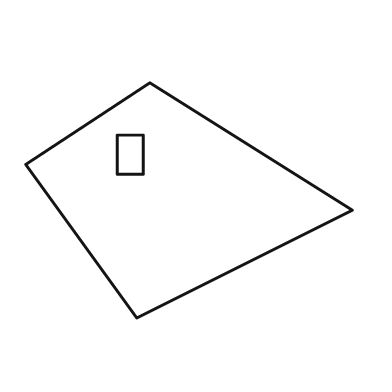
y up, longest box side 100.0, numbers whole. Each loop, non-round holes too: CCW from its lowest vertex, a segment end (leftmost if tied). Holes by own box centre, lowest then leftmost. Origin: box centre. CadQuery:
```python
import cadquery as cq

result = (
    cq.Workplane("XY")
    .moveTo(-16.0, -36.0)
    .lineTo(50.0, -3.0)
    .lineTo(-12.0, 36.0)
    .lineTo(-50.0, 11.0)
    .close()
    .moveTo(-22.0, 8.0)
    .lineTo(-14.0, 8.0)
    .lineTo(-14.0, 20.0)
    .lineTo(-22.0, 20.0)
    .close()
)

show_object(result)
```